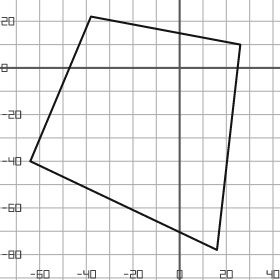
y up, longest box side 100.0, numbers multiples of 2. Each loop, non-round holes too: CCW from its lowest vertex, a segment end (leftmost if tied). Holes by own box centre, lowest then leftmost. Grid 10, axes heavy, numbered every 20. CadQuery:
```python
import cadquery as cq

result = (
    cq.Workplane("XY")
    .moveTo(16.0, -78.0)
    .lineTo(26.0, 10.0)
    .lineTo(-38.0, 22.0)
    .lineTo(-64.0, -40.0)
    .close()
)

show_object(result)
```